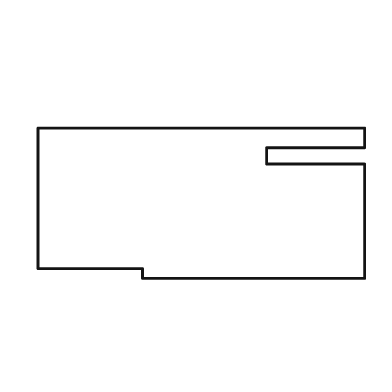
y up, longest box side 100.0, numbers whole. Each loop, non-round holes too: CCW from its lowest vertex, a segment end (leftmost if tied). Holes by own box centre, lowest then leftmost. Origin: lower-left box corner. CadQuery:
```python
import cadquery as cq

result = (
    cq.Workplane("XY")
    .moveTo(32.0, 0.0)
    .lineTo(100.0, 0.0)
    .lineTo(100.0, 35.0)
    .lineTo(70.0, 35.0)
    .lineTo(70.0, 40.0)
    .lineTo(100.0, 40.0)
    .lineTo(100.0, 46.0)
    .lineTo(0.0, 46.0)
    .lineTo(0.0, 3.0)
    .lineTo(32.0, 3.0)
    .close()
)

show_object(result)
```